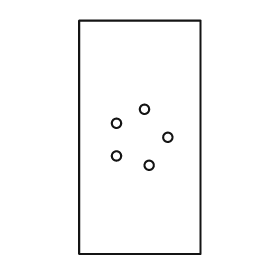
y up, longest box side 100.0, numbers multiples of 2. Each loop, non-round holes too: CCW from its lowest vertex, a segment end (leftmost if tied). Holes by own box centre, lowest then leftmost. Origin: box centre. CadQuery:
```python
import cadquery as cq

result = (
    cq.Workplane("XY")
    .moveTo(-26.0, -50.0)
    .lineTo(26.0, -50.0)
    .lineTo(26.0, 50.0)
    .lineTo(-26.0, 50.0)
    .close()
    .moveTo(4.0, -12.0)
    .circle(2.0)
    .moveTo(-10.0, -8.0)
    .circle(2.0)
    .moveTo(12.0, 0.0)
    .circle(2.0)
    .moveTo(-10.0, 6.0)
    .circle(2.0)
    .moveTo(2.0, 12.0)
    .circle(2.0)
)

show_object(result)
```